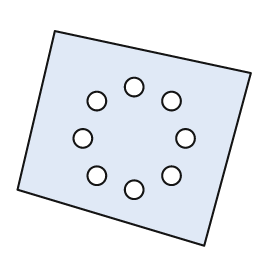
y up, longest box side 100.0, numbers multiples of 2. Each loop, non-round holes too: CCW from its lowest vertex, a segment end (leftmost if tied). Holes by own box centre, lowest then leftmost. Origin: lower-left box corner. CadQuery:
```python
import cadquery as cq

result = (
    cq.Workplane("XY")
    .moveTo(80.0, 0.0)
    .lineTo(100.0, 74.0)
    .lineTo(16.0, 92.0)
    .lineTo(0.0, 24.0)
    .close()
    .moveTo(50.0, 24.0)
    .circle(4.0)
    .moveTo(34.0, 30.0)
    .circle(4.0)
    .moveTo(66.0, 30.0)
    .circle(4.0)
    .moveTo(28.0, 46.0)
    .circle(4.0)
    .moveTo(72.0, 46.0)
    .circle(4.0)
    .moveTo(34.0, 62.0)
    .circle(4.0)
    .moveTo(66.0, 62.0)
    .circle(4.0)
    .moveTo(50.0, 68.0)
    .circle(4.0)
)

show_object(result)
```